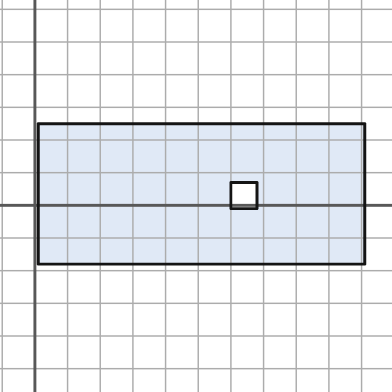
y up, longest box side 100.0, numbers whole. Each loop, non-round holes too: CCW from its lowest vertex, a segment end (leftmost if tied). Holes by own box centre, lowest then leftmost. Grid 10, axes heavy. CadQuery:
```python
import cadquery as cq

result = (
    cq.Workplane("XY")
    .moveTo(1.0, -18.0)
    .lineTo(101.0, -18.0)
    .lineTo(101.0, 25.0)
    .lineTo(1.0, 25.0)
    .close()
    .moveTo(60.0, -1.0)
    .lineTo(68.0, -1.0)
    .lineTo(68.0, 7.0)
    .lineTo(60.0, 7.0)
    .close()
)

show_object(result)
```